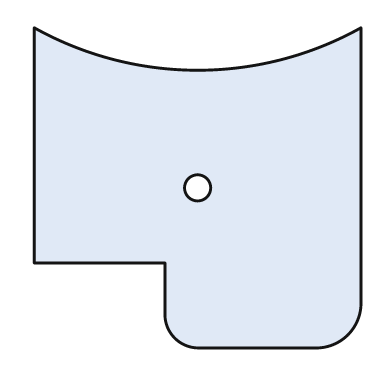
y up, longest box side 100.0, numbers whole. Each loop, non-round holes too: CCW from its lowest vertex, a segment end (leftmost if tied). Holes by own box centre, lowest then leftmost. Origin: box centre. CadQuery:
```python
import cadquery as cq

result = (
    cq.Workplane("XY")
    .moveTo(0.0, -49.0)
    .lineTo(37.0, -49.0)
    .threePointArc((46.0, -45.0), (50.0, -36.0))
    .lineTo(50.0, 49.0)
    .threePointArc((0.0, 36.0), (-50.0, 49.0))
    .lineTo(-50.0, -23.0)
    .lineTo(-10.0, -23.0)
    .lineTo(-10.0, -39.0)
    .threePointArc((-7.0, -46.0), (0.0, -49.0))
    .close()
    .moveTo(0.0, 0.0)
    .circle(4.0)
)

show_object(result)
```